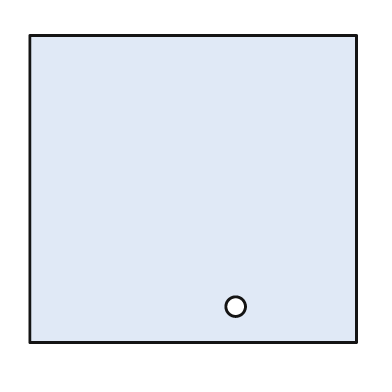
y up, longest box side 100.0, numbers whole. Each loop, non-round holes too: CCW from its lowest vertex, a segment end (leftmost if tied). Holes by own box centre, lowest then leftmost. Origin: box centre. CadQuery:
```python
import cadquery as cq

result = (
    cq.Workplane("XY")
    .moveTo(-50.0, -47.0)
    .lineTo(50.0, -47.0)
    .lineTo(50.0, 47.0)
    .lineTo(-50.0, 47.0)
    .close()
    .moveTo(13.0, -36.0)
    .circle(3.0)
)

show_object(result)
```